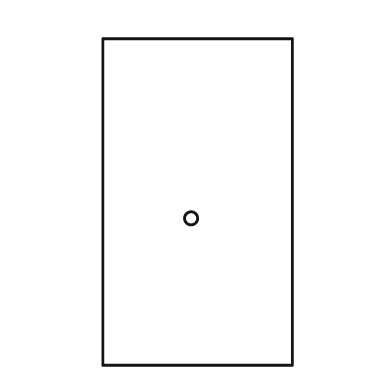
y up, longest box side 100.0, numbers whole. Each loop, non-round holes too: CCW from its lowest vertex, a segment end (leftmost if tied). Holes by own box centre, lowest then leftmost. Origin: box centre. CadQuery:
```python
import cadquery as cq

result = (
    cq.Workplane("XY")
    .moveTo(-29.0, -50.0)
    .lineTo(29.0, -50.0)
    .lineTo(29.0, 50.0)
    .lineTo(-29.0, 50.0)
    .close()
    .moveTo(-2.0, -5.0)
    .circle(2.0)
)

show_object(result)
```